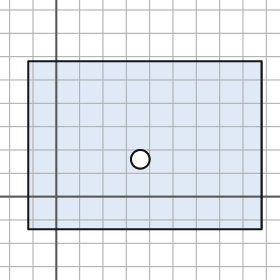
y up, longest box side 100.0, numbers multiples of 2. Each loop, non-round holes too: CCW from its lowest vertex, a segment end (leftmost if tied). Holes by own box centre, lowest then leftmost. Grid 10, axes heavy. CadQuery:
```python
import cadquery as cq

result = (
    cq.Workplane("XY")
    .moveTo(-12.0, -14.0)
    .lineTo(88.0, -14.0)
    .lineTo(88.0, 58.0)
    .lineTo(-12.0, 58.0)
    .close()
    .moveTo(36.0, 16.0)
    .circle(4.0)
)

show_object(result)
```